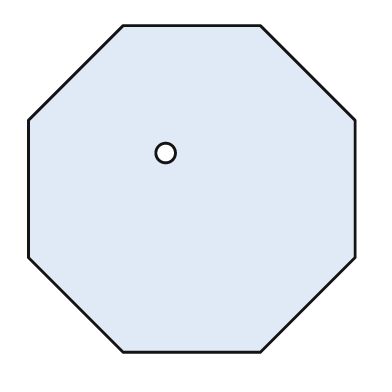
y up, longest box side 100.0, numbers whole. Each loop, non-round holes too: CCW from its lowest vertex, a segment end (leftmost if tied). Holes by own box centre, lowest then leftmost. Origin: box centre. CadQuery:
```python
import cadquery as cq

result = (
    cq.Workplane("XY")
    .moveTo(-21.0, -50.0)
    .lineTo(21.0, -50.0)
    .lineTo(50.0, -21.0)
    .lineTo(50.0, 21.0)
    .lineTo(21.0, 50.0)
    .lineTo(-21.0, 50.0)
    .lineTo(-50.0, 21.0)
    .lineTo(-50.0, -21.0)
    .close()
    .moveTo(-8.0, 11.0)
    .circle(3.0)
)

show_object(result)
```